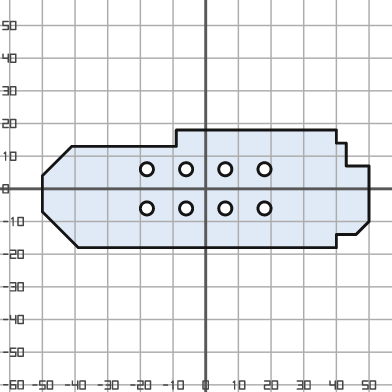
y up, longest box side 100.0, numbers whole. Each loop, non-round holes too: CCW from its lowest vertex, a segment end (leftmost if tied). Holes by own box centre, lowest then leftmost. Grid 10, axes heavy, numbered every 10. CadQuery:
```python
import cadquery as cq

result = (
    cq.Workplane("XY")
    .moveTo(-39.0, -18.0)
    .lineTo(40.0, -18.0)
    .lineTo(40.0, -14.0)
    .lineTo(46.0, -14.0)
    .lineTo(50.0, -10.0)
    .lineTo(50.0, 7.0)
    .lineTo(43.0, 7.0)
    .lineTo(43.0, 14.0)
    .lineTo(40.0, 14.0)
    .lineTo(40.0, 18.0)
    .lineTo(-9.0, 18.0)
    .lineTo(-9.0, 13.0)
    .lineTo(-41.0, 13.0)
    .lineTo(-50.0, 4.0)
    .lineTo(-50.0, -7.0)
    .close()
    .moveTo(-18.0, -6.0)
    .circle(2.0)
    .moveTo(-6.0, -6.0)
    .circle(2.0)
    .moveTo(6.0, -6.0)
    .circle(2.0)
    .moveTo(18.0, -6.0)
    .circle(2.0)
    .moveTo(-18.0, 6.0)
    .circle(2.0)
    .moveTo(-6.0, 6.0)
    .circle(2.0)
    .moveTo(6.0, 6.0)
    .circle(2.0)
    .moveTo(18.0, 6.0)
    .circle(2.0)
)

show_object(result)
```